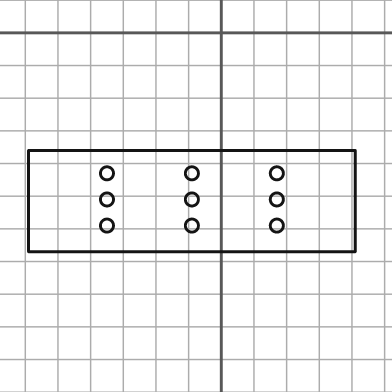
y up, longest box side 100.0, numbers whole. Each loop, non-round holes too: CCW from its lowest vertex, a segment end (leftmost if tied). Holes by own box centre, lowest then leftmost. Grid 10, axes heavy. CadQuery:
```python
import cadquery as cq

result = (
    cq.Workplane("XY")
    .moveTo(-59.0, -67.0)
    .lineTo(41.0, -67.0)
    .lineTo(41.0, -36.0)
    .lineTo(-59.0, -36.0)
    .close()
    .moveTo(-35.0, -59.0)
    .circle(2.0)
    .moveTo(-9.0, -59.0)
    .circle(2.0)
    .moveTo(17.0, -59.0)
    .circle(2.0)
    .moveTo(-35.0, -51.0)
    .circle(2.0)
    .moveTo(-9.0, -51.0)
    .circle(2.0)
    .moveTo(17.0, -51.0)
    .circle(2.0)
    .moveTo(-35.0, -43.0)
    .circle(2.0)
    .moveTo(-9.0, -43.0)
    .circle(2.0)
    .moveTo(17.0, -43.0)
    .circle(2.0)
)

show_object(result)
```